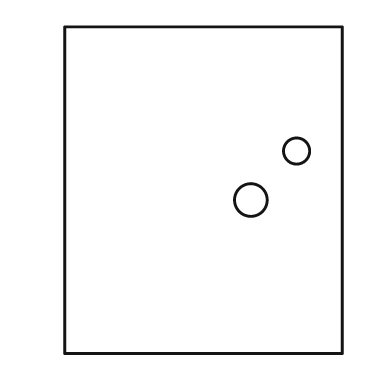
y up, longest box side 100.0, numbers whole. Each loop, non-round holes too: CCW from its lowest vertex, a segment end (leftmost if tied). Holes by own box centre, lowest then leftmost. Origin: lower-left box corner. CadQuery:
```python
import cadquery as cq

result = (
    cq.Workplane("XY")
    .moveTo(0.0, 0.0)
    .lineTo(85.0, 0.0)
    .lineTo(85.0, 100.0)
    .lineTo(0.0, 100.0)
    .close()
    .moveTo(57.0, 47.0)
    .circle(5.0)
    .moveTo(71.0, 62.0)
    .circle(4.0)
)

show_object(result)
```